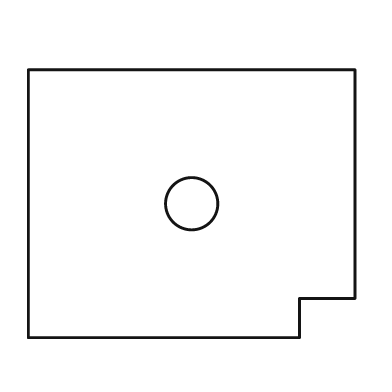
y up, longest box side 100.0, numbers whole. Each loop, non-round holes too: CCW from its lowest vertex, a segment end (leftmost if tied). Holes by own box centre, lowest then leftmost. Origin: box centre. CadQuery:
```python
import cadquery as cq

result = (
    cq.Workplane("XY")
    .moveTo(-50.0, -41.0)
    .lineTo(33.0, -41.0)
    .lineTo(33.0, -29.0)
    .lineTo(50.0, -29.0)
    .lineTo(50.0, 41.0)
    .lineTo(-50.0, 41.0)
    .close()
    .moveTo(0.0, 0.0)
    .circle(8.0)
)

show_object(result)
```